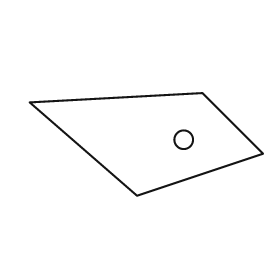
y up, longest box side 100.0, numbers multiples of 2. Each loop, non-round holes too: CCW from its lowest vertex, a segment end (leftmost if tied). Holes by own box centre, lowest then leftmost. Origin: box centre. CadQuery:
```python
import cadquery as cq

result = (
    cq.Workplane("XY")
    .moveTo(-4.0, -22.0)
    .lineTo(50.0, -4.0)
    .lineTo(24.0, 22.0)
    .lineTo(-50.0, 18.0)
    .close()
    .moveTo(16.0, 2.0)
    .circle(4.0)
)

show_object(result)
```